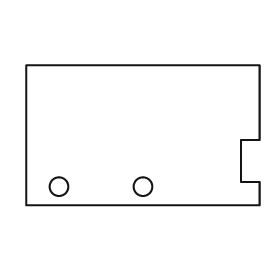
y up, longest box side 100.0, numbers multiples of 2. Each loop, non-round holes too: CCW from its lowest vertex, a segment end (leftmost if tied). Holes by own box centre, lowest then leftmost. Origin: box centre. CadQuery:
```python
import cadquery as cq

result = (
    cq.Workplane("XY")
    .moveTo(-50.0, -30.0)
    .lineTo(50.0, -30.0)
    .lineTo(50.0, -20.0)
    .lineTo(42.0, -20.0)
    .lineTo(42.0, -2.0)
    .lineTo(50.0, -2.0)
    .lineTo(50.0, 30.0)
    .lineTo(-50.0, 30.0)
    .close()
    .moveTo(-36.0, -22.0)
    .circle(4.0)
    .moveTo(0.0, -22.0)
    .circle(4.0)
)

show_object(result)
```